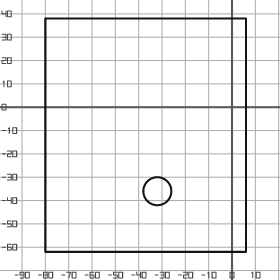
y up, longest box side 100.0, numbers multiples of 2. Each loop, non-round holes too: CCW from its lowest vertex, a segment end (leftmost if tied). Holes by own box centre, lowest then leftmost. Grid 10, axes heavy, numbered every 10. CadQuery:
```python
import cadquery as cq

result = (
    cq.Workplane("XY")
    .moveTo(-80.0, -62.0)
    .lineTo(6.0, -62.0)
    .lineTo(6.0, 38.0)
    .lineTo(-80.0, 38.0)
    .close()
    .moveTo(-32.0, -36.0)
    .circle(6.0)
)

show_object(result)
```